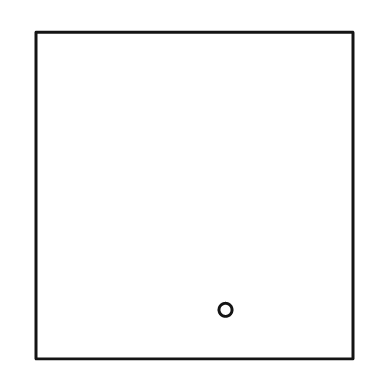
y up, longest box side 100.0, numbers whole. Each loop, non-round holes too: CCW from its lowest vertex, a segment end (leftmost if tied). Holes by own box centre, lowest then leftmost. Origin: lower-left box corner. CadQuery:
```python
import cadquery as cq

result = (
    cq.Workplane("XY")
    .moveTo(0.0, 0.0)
    .lineTo(97.0, 0.0)
    .lineTo(97.0, 100.0)
    .lineTo(0.0, 100.0)
    .close()
    .moveTo(58.0, 15.0)
    .circle(2.0)
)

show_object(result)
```